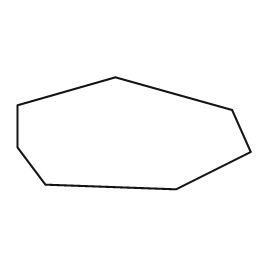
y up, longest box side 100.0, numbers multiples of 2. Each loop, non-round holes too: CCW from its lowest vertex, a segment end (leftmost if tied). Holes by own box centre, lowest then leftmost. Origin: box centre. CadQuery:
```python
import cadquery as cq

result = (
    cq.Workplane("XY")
    .moveTo(18.0, -24.0)
    .lineTo(50.0, -8.0)
    .lineTo(42.0, 10.0)
    .lineTo(-8.0, 24.0)
    .lineTo(-50.0, 12.0)
    .lineTo(-50.0, -6.0)
    .lineTo(-38.0, -22.0)
    .close()
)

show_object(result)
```